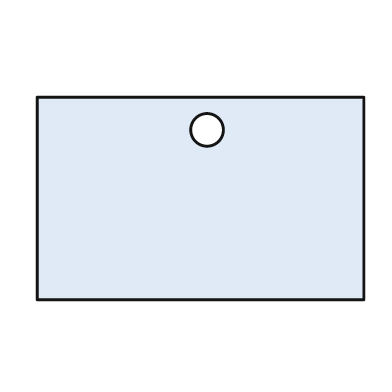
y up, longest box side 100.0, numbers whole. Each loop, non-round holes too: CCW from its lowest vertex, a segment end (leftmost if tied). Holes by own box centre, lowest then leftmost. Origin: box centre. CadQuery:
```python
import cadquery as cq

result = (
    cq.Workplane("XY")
    .moveTo(-50.0, -31.0)
    .lineTo(50.0, -31.0)
    .lineTo(50.0, 31.0)
    .lineTo(-50.0, 31.0)
    .close()
    .moveTo(2.0, 21.0)
    .circle(5.0)
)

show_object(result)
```